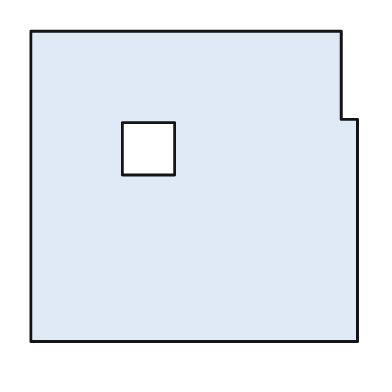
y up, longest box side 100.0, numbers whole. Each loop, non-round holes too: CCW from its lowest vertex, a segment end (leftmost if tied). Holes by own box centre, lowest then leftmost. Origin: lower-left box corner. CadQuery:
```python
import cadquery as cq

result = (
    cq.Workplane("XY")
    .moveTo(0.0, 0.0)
    .lineTo(100.0, 0.0)
    .lineTo(100.0, 68.0)
    .lineTo(95.0, 68.0)
    .lineTo(95.0, 95.0)
    .lineTo(0.0, 95.0)
    .close()
    .moveTo(28.0, 51.0)
    .lineTo(44.0, 51.0)
    .lineTo(44.0, 67.0)
    .lineTo(28.0, 67.0)
    .close()
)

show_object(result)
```